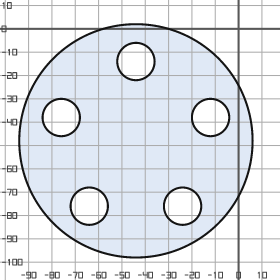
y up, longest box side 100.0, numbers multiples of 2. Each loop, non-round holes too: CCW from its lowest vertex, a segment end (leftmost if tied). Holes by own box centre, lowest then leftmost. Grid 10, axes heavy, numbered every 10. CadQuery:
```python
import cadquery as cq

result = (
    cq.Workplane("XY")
    .moveTo(-44.0, -48.0)
    .circle(50.0)
    .moveTo(-64.0, -76.0)
    .circle(8.0)
    .moveTo(-24.0, -76.0)
    .circle(8.0)
    .moveTo(-76.0, -38.0)
    .circle(8.0)
    .moveTo(-12.0, -38.0)
    .circle(8.0)
    .moveTo(-44.0, -14.0)
    .circle(8.0)
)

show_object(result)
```